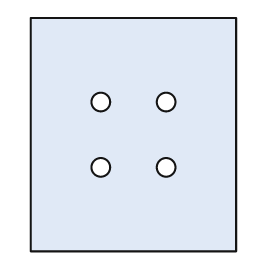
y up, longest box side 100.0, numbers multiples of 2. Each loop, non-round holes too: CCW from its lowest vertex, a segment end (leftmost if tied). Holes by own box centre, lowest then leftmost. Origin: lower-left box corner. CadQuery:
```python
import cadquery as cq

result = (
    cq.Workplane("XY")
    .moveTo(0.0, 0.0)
    .lineTo(88.0, 0.0)
    .lineTo(88.0, 100.0)
    .lineTo(0.0, 100.0)
    .close()
    .moveTo(30.0, 36.0)
    .circle(4.0)
    .moveTo(58.0, 36.0)
    .circle(4.0)
    .moveTo(30.0, 64.0)
    .circle(4.0)
    .moveTo(58.0, 64.0)
    .circle(4.0)
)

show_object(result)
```